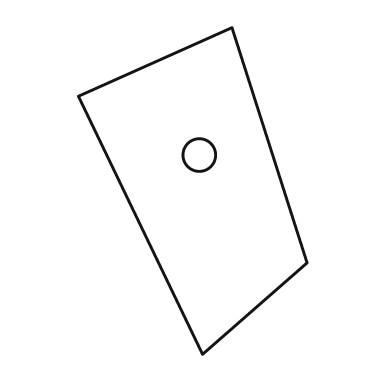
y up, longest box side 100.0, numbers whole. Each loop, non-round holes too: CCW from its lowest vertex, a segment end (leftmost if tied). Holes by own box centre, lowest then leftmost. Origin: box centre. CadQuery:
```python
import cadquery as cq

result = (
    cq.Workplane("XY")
    .moveTo(3.0, -50.0)
    .lineTo(35.0, -22.0)
    .lineTo(12.0, 50.0)
    .lineTo(-35.0, 29.0)
    .close()
    .moveTo(2.0, 11.0)
    .circle(5.0)
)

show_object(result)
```